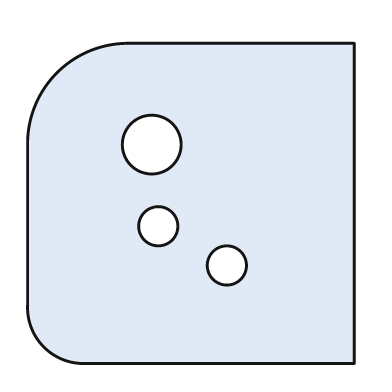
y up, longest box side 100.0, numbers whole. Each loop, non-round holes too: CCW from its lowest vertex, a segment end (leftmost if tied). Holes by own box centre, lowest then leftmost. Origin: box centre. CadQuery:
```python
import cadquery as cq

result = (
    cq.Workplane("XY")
    .moveTo(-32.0, -49.0)
    .lineTo(50.0, -49.0)
    .lineTo(50.0, 49.0)
    .lineTo(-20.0, 49.0)
    .threePointArc((-41.0, 40.0), (-50.0, 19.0))
    .lineTo(-50.0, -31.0)
    .threePointArc((-45.0, -44.0), (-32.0, -49.0))
    .close()
    .moveTo(11.0, -19.0)
    .circle(6.0)
    .moveTo(-10.0, -7.0)
    .circle(6.0)
    .moveTo(-12.0, 18.0)
    .circle(9.0)
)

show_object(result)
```